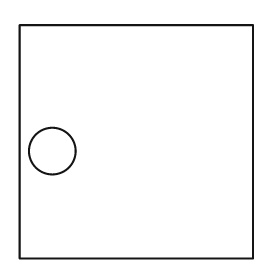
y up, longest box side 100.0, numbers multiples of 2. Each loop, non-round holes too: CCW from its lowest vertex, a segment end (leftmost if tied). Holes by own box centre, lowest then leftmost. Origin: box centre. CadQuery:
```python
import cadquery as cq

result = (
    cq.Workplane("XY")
    .moveTo(-50.0, -50.0)
    .lineTo(50.0, -50.0)
    .lineTo(50.0, 50.0)
    .lineTo(-50.0, 50.0)
    .close()
    .moveTo(-36.0, -4.0)
    .circle(10.0)
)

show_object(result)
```